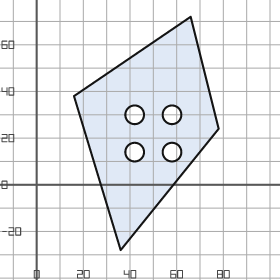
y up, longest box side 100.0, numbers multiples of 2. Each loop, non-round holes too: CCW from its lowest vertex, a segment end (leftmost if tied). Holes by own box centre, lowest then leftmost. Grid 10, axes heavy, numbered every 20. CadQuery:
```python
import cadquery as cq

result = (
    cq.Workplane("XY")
    .moveTo(36.0, -28.0)
    .lineTo(78.0, 24.0)
    .lineTo(66.0, 72.0)
    .lineTo(16.0, 38.0)
    .close()
    .moveTo(42.0, 14.0)
    .circle(4.0)
    .moveTo(58.0, 14.0)
    .circle(4.0)
    .moveTo(42.0, 30.0)
    .circle(4.0)
    .moveTo(58.0, 30.0)
    .circle(4.0)
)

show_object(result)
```